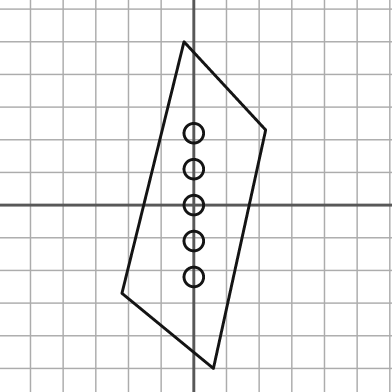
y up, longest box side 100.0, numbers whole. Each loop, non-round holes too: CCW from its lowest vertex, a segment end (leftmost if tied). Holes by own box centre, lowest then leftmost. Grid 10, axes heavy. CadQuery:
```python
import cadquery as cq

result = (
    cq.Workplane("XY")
    .moveTo(6.0, -50.0)
    .lineTo(22.0, 23.0)
    .lineTo(-3.0, 50.0)
    .lineTo(-22.0, -27.0)
    .close()
    .moveTo(0.0, -22.0)
    .circle(3.0)
    .moveTo(0.0, -11.0)
    .circle(3.0)
    .moveTo(0.0, 0.0)
    .circle(3.0)
    .moveTo(0.0, 11.0)
    .circle(3.0)
    .moveTo(0.0, 22.0)
    .circle(3.0)
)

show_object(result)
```